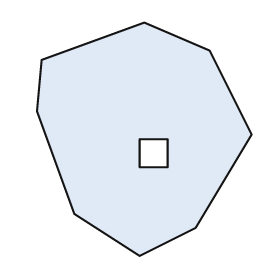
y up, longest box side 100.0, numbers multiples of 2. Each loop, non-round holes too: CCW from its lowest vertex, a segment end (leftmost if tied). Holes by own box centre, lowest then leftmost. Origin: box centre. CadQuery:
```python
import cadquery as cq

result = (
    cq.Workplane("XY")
    .moveTo(-2.0, -50.0)
    .lineTo(22.0, -38.0)
    .lineTo(46.0, 2.0)
    .lineTo(28.0, 38.0)
    .lineTo(0.0, 50.0)
    .lineTo(-44.0, 34.0)
    .lineTo(-46.0, 12.0)
    .lineTo(-30.0, -32.0)
    .close()
    .moveTo(-2.0, -12.0)
    .lineTo(10.0, -12.0)
    .lineTo(10.0, 0.0)
    .lineTo(-2.0, 0.0)
    .close()
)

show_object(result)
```